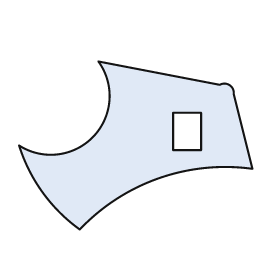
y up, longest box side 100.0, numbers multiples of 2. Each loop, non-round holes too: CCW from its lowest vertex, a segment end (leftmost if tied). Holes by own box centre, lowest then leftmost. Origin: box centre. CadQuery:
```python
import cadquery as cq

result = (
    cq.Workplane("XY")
    .moveTo(-24.0, -36.0)
    .threePointArc((10.0, -14.0), (50.0, -10.0))
    .lineTo(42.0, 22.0)
    .threePointArc((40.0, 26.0), (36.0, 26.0))
    .lineTo(-16.0, 36.0)
    .threePointArc((-18.0, 4.0), (-50.0, 0.0))
    .threePointArc((-40.0, -20.0), (-24.0, -36.0))
    .close()
    .moveTo(16.0, -2.0)
    .lineTo(28.0, -2.0)
    .lineTo(28.0, 14.0)
    .lineTo(16.0, 14.0)
    .close()
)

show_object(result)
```